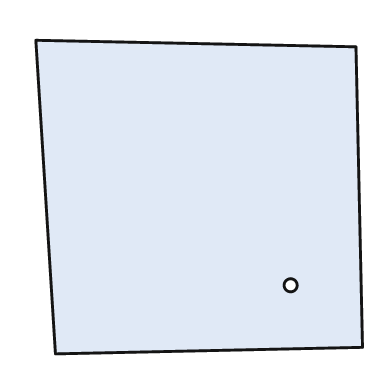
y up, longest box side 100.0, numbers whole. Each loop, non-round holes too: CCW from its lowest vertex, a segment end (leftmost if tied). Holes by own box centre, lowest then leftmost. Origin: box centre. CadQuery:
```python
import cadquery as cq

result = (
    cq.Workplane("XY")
    .moveTo(-44.0, -48.0)
    .lineTo(50.0, -46.0)
    .lineTo(48.0, 46.0)
    .lineTo(-50.0, 48.0)
    .close()
    .moveTo(28.0, -27.0)
    .circle(2.0)
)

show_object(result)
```